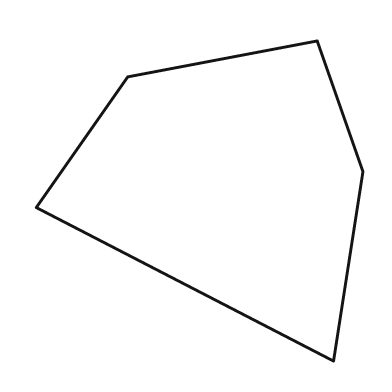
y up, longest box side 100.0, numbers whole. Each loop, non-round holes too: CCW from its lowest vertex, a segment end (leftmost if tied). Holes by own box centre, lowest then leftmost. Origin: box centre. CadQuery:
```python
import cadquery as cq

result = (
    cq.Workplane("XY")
    .moveTo(41.0, -49.0)
    .lineTo(50.0, 9.0)
    .lineTo(36.0, 49.0)
    .lineTo(-22.0, 38.0)
    .lineTo(-50.0, -2.0)
    .close()
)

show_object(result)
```